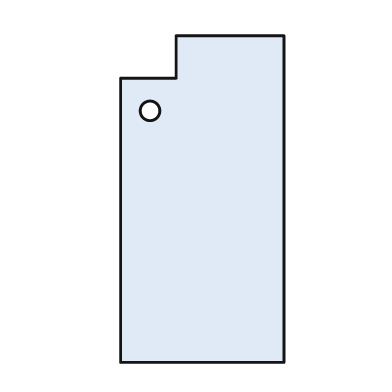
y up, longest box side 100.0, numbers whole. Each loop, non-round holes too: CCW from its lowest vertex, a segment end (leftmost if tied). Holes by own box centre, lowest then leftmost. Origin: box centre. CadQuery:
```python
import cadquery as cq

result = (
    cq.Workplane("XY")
    .moveTo(-25.0, -50.0)
    .lineTo(25.0, -50.0)
    .lineTo(25.0, 50.0)
    .lineTo(-8.0, 50.0)
    .lineTo(-8.0, 37.0)
    .lineTo(-25.0, 37.0)
    .close()
    .moveTo(-16.0, 27.0)
    .circle(3.0)
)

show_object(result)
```